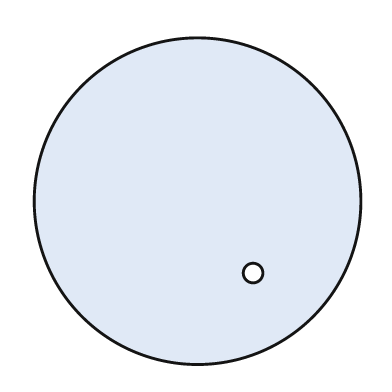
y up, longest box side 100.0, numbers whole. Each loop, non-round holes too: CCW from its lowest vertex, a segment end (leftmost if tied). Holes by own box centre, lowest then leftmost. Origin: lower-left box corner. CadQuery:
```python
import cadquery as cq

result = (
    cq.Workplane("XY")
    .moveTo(50.0, 50.0)
    .circle(50.0)
    .moveTo(67.0, 28.0)
    .circle(3.0)
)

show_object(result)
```